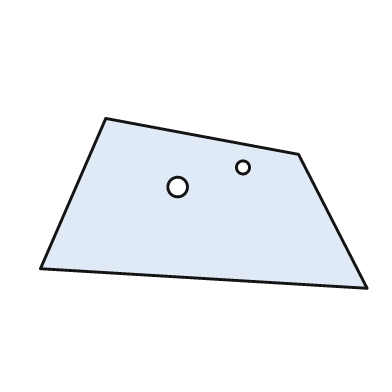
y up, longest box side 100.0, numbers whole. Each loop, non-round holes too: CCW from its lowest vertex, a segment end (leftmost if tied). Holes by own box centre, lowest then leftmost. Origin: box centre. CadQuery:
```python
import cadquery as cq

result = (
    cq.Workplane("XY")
    .moveTo(50.0, -26.0)
    .lineTo(29.0, 15.0)
    .lineTo(-30.0, 26.0)
    .lineTo(-50.0, -20.0)
    .close()
    .moveTo(-8.0, 5.0)
    .circle(3.0)
    .moveTo(12.0, 11.0)
    .circle(2.0)
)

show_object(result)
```